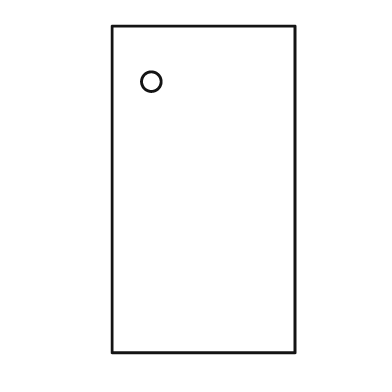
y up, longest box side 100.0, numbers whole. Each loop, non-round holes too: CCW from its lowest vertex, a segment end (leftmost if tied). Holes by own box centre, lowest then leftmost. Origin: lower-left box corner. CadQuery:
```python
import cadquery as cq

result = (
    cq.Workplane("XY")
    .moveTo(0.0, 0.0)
    .lineTo(56.0, 0.0)
    .lineTo(56.0, 100.0)
    .lineTo(0.0, 100.0)
    .close()
    .moveTo(12.0, 83.0)
    .circle(3.0)
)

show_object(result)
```